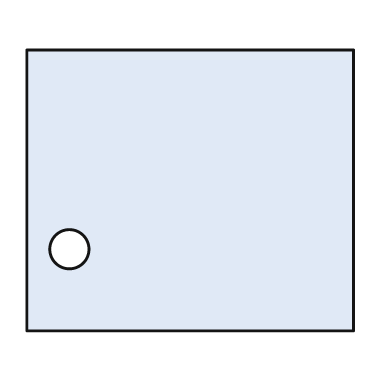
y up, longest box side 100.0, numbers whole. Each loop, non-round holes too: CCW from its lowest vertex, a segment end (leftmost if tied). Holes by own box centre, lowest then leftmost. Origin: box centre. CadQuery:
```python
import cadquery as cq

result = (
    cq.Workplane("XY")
    .moveTo(-50.0, -43.0)
    .lineTo(50.0, -43.0)
    .lineTo(50.0, 43.0)
    .lineTo(-50.0, 43.0)
    .close()
    .moveTo(-37.0, -18.0)
    .circle(6.0)
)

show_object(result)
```